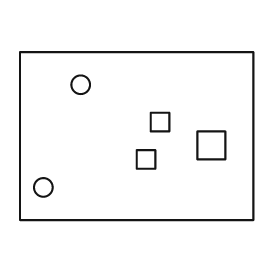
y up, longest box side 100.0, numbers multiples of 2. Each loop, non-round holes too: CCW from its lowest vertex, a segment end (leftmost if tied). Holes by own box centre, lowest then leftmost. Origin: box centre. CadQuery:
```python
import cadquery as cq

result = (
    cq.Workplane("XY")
    .moveTo(-50.0, -36.0)
    .lineTo(50.0, -36.0)
    .lineTo(50.0, 36.0)
    .lineTo(-50.0, 36.0)
    .close()
    .moveTo(-40.0, -22.0)
    .circle(4.0)
    .moveTo(0.0, -14.0)
    .lineTo(8.0, -14.0)
    .lineTo(8.0, -6.0)
    .lineTo(0.0, -6.0)
    .close()
    .moveTo(26.0, -10.0)
    .lineTo(38.0, -10.0)
    .lineTo(38.0, 2.0)
    .lineTo(26.0, 2.0)
    .close()
    .moveTo(6.0, 2.0)
    .lineTo(14.0, 2.0)
    .lineTo(14.0, 10.0)
    .lineTo(6.0, 10.0)
    .close()
    .moveTo(-24.0, 22.0)
    .circle(4.0)
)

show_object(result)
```